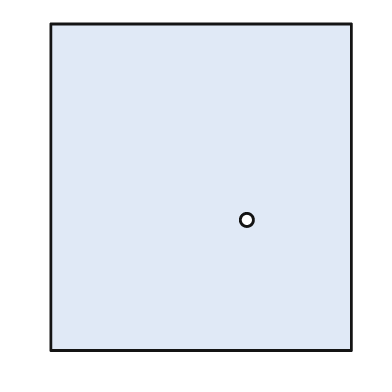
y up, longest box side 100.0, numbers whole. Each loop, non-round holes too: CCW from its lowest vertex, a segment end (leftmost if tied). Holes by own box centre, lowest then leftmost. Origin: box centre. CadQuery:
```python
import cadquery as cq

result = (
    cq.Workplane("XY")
    .moveTo(-46.0, -50.0)
    .lineTo(46.0, -50.0)
    .lineTo(46.0, 50.0)
    .lineTo(-46.0, 50.0)
    .close()
    .moveTo(14.0, -10.0)
    .circle(2.0)
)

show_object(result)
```